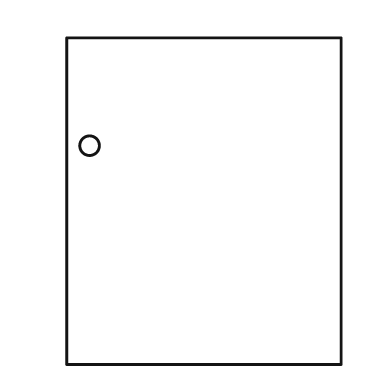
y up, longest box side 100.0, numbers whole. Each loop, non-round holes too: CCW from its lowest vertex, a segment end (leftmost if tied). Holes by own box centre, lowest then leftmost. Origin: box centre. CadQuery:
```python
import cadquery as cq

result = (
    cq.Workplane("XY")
    .moveTo(-42.0, -50.0)
    .lineTo(42.0, -50.0)
    .lineTo(42.0, 50.0)
    .lineTo(-42.0, 50.0)
    .close()
    .moveTo(-35.0, 17.0)
    .circle(3.0)
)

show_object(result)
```